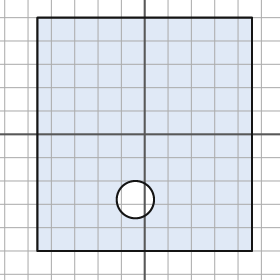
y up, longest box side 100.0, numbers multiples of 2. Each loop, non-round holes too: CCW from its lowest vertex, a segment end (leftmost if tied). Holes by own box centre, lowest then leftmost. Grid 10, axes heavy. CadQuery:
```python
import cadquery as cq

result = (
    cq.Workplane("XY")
    .moveTo(-46.0, -50.0)
    .lineTo(46.0, -50.0)
    .lineTo(46.0, 50.0)
    .lineTo(-46.0, 50.0)
    .close()
    .moveTo(-4.0, -28.0)
    .circle(8.0)
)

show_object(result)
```